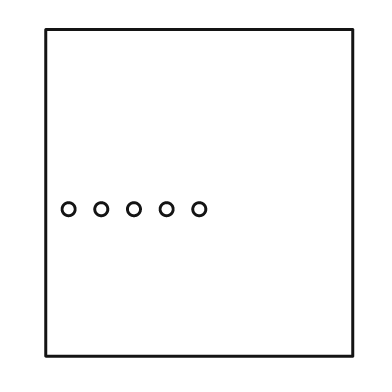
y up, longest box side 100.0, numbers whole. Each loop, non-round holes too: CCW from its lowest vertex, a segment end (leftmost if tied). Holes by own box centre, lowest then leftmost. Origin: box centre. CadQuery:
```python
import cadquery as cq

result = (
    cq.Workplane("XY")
    .moveTo(-47.0, -50.0)
    .lineTo(47.0, -50.0)
    .lineTo(47.0, 50.0)
    .lineTo(-47.0, 50.0)
    .close()
    .moveTo(-40.0, -5.0)
    .circle(2.0)
    .moveTo(-30.0, -5.0)
    .circle(2.0)
    .moveTo(-20.0, -5.0)
    .circle(2.0)
    .moveTo(-10.0, -5.0)
    .circle(2.0)
    .moveTo(0.0, -5.0)
    .circle(2.0)
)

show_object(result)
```